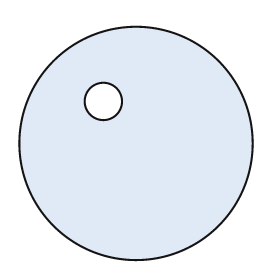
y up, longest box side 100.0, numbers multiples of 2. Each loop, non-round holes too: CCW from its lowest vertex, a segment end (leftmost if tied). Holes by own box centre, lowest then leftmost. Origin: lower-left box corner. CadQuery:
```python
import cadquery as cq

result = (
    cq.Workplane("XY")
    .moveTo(50.0, 50.0)
    .circle(50.0)
    .moveTo(36.0, 68.0)
    .circle(8.0)
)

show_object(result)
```